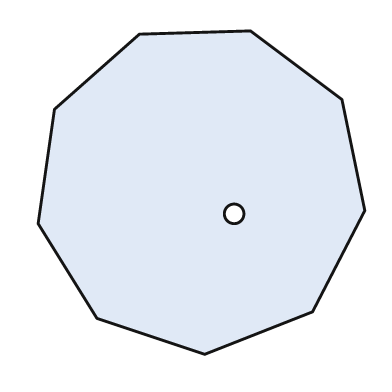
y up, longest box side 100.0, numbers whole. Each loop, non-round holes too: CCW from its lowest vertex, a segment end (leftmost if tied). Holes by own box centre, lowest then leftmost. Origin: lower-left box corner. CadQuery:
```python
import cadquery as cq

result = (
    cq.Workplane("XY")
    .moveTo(51.0, 0.0)
    .lineTo(84.0, 13.0)
    .lineTo(100.0, 44.0)
    .lineTo(93.0, 78.0)
    .lineTo(65.0, 99.0)
    .lineTo(31.0, 98.0)
    .lineTo(5.0, 75.0)
    .lineTo(0.0, 40.0)
    .lineTo(18.0, 11.0)
    .close()
    .moveTo(60.0, 43.0)
    .circle(3.0)
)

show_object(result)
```